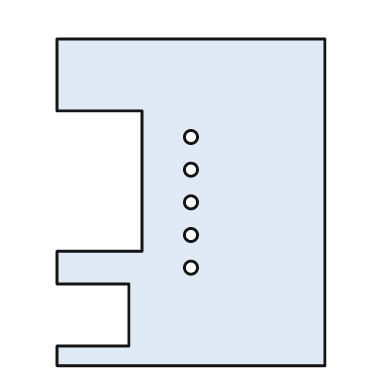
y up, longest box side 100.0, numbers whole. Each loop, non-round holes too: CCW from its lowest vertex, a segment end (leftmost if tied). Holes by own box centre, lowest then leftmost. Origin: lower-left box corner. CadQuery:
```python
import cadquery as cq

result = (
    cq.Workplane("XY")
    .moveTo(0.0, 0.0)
    .lineTo(82.0, 0.0)
    .lineTo(82.0, 100.0)
    .lineTo(0.0, 100.0)
    .lineTo(0.0, 78.0)
    .lineTo(26.0, 78.0)
    .lineTo(26.0, 35.0)
    .lineTo(0.0, 35.0)
    .lineTo(0.0, 25.0)
    .lineTo(22.0, 25.0)
    .lineTo(22.0, 6.0)
    .lineTo(0.0, 6.0)
    .close()
    .moveTo(41.0, 30.0)
    .circle(2.0)
    .moveTo(41.0, 40.0)
    .circle(2.0)
    .moveTo(41.0, 50.0)
    .circle(2.0)
    .moveTo(41.0, 60.0)
    .circle(2.0)
    .moveTo(41.0, 70.0)
    .circle(2.0)
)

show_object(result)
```